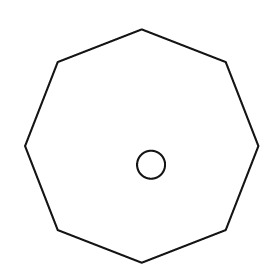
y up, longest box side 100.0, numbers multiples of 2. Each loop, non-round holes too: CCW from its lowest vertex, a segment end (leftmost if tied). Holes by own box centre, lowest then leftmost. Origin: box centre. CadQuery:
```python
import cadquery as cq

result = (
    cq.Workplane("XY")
    .moveTo(0.0, -50.0)
    .lineTo(36.0, -36.0)
    .lineTo(50.0, 0.0)
    .lineTo(36.0, 36.0)
    .lineTo(0.0, 50.0)
    .lineTo(-36.0, 36.0)
    .lineTo(-50.0, 0.0)
    .lineTo(-36.0, -36.0)
    .close()
    .moveTo(4.0, -8.0)
    .circle(6.0)
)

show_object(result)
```